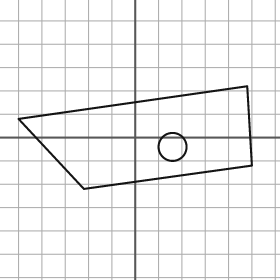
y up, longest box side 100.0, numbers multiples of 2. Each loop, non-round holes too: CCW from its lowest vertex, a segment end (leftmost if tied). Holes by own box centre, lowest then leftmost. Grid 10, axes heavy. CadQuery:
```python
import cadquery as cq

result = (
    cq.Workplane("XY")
    .moveTo(-22.0, -22.0)
    .lineTo(50.0, -12.0)
    .lineTo(48.0, 22.0)
    .lineTo(-50.0, 8.0)
    .close()
    .moveTo(16.0, -4.0)
    .circle(6.0)
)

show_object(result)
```